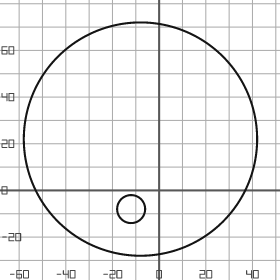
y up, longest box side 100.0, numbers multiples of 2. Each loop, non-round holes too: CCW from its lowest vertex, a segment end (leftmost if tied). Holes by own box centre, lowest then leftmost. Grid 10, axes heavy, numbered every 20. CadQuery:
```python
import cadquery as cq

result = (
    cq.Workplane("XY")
    .moveTo(-8.0, 22.0)
    .circle(50.0)
    .moveTo(-12.0, -8.0)
    .circle(6.0)
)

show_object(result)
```